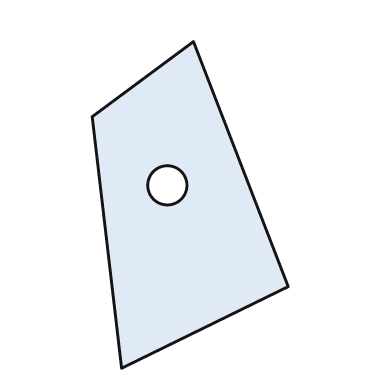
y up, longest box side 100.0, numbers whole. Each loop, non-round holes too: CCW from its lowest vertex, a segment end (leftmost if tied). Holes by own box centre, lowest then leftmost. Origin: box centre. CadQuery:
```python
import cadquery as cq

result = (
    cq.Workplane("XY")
    .moveTo(-21.0, -50.0)
    .lineTo(30.0, -25.0)
    .lineTo(1.0, 50.0)
    .lineTo(-30.0, 27.0)
    .close()
    .moveTo(-7.0, 6.0)
    .circle(6.0)
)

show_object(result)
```